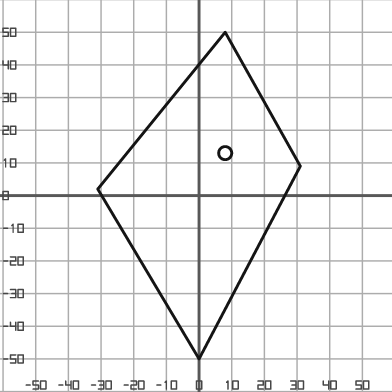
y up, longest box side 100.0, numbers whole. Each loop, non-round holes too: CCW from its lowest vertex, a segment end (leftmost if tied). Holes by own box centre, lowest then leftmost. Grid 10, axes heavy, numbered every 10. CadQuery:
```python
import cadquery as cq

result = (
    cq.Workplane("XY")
    .moveTo(0.0, -50.0)
    .lineTo(31.0, 9.0)
    .lineTo(8.0, 50.0)
    .lineTo(-31.0, 2.0)
    .close()
    .moveTo(8.0, 13.0)
    .circle(2.0)
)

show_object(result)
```